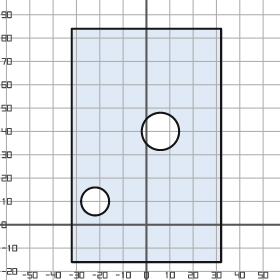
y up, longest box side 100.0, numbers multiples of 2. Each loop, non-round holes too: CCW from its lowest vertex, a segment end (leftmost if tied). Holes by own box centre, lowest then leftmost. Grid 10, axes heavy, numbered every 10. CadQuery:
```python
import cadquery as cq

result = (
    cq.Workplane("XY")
    .moveTo(-32.0, -16.0)
    .lineTo(32.0, -16.0)
    .lineTo(32.0, 84.0)
    .lineTo(-32.0, 84.0)
    .close()
    .moveTo(-22.0, 10.0)
    .circle(6.0)
    .moveTo(6.0, 40.0)
    .circle(8.0)
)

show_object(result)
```